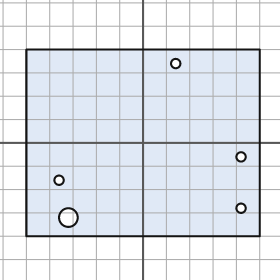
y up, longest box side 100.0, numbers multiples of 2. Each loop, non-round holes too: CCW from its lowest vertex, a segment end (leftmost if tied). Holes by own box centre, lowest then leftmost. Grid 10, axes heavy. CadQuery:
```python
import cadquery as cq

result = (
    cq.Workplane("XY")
    .moveTo(-50.0, -40.0)
    .lineTo(50.0, -40.0)
    .lineTo(50.0, 40.0)
    .lineTo(-50.0, 40.0)
    .close()
    .moveTo(-32.0, -32.0)
    .circle(4.0)
    .moveTo(42.0, -28.0)
    .circle(2.0)
    .moveTo(-36.0, -16.0)
    .circle(2.0)
    .moveTo(42.0, -6.0)
    .circle(2.0)
    .moveTo(14.0, 34.0)
    .circle(2.0)
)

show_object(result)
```